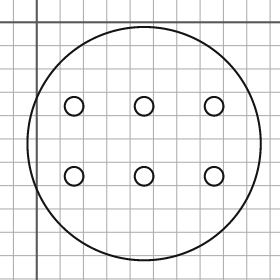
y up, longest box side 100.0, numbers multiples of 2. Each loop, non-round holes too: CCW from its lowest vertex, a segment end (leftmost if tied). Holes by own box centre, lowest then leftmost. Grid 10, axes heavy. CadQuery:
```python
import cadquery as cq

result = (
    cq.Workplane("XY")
    .moveTo(46.0, -52.0)
    .circle(50.0)
    .moveTo(16.0, -66.0)
    .circle(4.0)
    .moveTo(46.0, -66.0)
    .circle(4.0)
    .moveTo(76.0, -66.0)
    .circle(4.0)
    .moveTo(16.0, -36.0)
    .circle(4.0)
    .moveTo(46.0, -36.0)
    .circle(4.0)
    .moveTo(76.0, -36.0)
    .circle(4.0)
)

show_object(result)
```